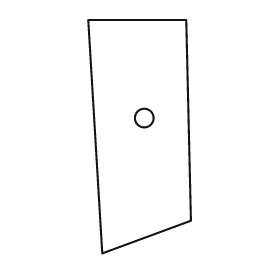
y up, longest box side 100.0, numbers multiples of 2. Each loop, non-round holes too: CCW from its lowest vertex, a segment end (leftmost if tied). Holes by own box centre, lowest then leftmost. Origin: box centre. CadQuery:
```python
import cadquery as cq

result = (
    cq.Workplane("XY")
    .moveTo(-16.0, -50.0)
    .lineTo(22.0, -36.0)
    .lineTo(20.0, 50.0)
    .lineTo(-22.0, 50.0)
    .close()
    .moveTo(2.0, 8.0)
    .circle(4.0)
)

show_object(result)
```